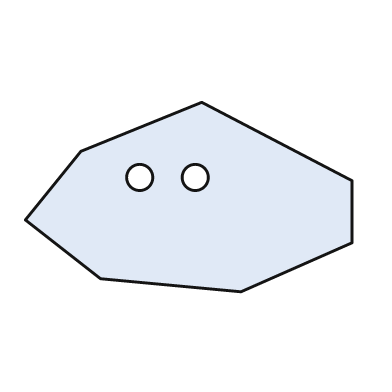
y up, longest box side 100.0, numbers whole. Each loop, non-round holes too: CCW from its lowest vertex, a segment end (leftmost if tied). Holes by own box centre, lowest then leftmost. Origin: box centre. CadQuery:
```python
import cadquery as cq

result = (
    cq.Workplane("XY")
    .moveTo(16.0, -29.0)
    .lineTo(50.0, -14.0)
    .lineTo(50.0, 5.0)
    .lineTo(4.0, 29.0)
    .lineTo(-33.0, 14.0)
    .lineTo(-50.0, -7.0)
    .lineTo(-27.0, -25.0)
    .close()
    .moveTo(-15.0, 6.0)
    .circle(4.0)
    .moveTo(2.0, 6.0)
    .circle(4.0)
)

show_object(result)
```